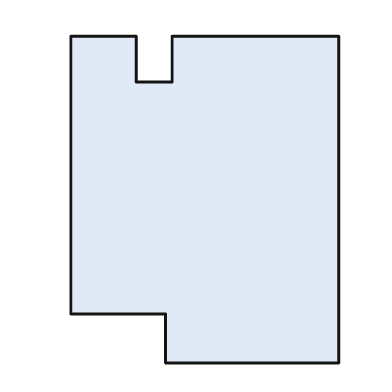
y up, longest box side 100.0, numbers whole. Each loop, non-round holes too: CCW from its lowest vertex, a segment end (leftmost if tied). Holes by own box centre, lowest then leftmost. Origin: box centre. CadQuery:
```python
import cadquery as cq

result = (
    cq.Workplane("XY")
    .moveTo(-12.0, -50.0)
    .lineTo(41.0, -50.0)
    .lineTo(41.0, 50.0)
    .lineTo(-10.0, 50.0)
    .lineTo(-10.0, 36.0)
    .lineTo(-21.0, 36.0)
    .lineTo(-21.0, 50.0)
    .lineTo(-41.0, 50.0)
    .lineTo(-41.0, -35.0)
    .lineTo(-12.0, -35.0)
    .close()
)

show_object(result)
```